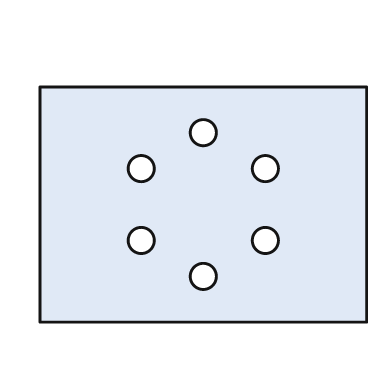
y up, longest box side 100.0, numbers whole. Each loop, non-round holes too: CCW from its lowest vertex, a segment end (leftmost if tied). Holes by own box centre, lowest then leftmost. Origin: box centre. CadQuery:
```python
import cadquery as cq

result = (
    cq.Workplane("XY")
    .moveTo(-50.0, -36.0)
    .lineTo(50.0, -36.0)
    .lineTo(50.0, 36.0)
    .lineTo(-50.0, 36.0)
    .close()
    .moveTo(0.0, -22.0)
    .circle(4.0)
    .moveTo(-19.0, -11.0)
    .circle(4.0)
    .moveTo(19.0, -11.0)
    .circle(4.0)
    .moveTo(-19.0, 11.0)
    .circle(4.0)
    .moveTo(19.0, 11.0)
    .circle(4.0)
    .moveTo(0.0, 22.0)
    .circle(4.0)
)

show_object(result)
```